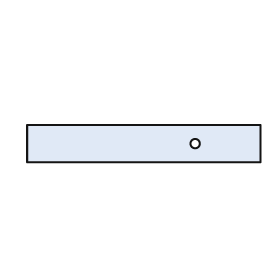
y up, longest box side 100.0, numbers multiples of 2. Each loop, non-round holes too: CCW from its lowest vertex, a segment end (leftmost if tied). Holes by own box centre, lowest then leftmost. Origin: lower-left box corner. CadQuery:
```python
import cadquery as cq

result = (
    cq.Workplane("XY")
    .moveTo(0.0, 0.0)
    .lineTo(100.0, 0.0)
    .lineTo(100.0, 16.0)
    .lineTo(0.0, 16.0)
    .close()
    .moveTo(72.0, 8.0)
    .circle(2.0)
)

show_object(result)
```